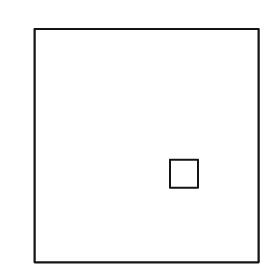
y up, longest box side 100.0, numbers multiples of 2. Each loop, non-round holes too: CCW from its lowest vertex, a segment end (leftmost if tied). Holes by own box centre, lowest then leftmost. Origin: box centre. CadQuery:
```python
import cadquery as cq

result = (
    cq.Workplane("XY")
    .moveTo(-48.0, -50.0)
    .lineTo(48.0, -50.0)
    .lineTo(48.0, 50.0)
    .lineTo(-48.0, 50.0)
    .close()
    .moveTo(10.0, -18.0)
    .lineTo(22.0, -18.0)
    .lineTo(22.0, -6.0)
    .lineTo(10.0, -6.0)
    .close()
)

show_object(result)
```